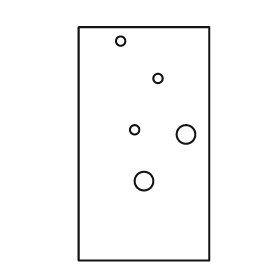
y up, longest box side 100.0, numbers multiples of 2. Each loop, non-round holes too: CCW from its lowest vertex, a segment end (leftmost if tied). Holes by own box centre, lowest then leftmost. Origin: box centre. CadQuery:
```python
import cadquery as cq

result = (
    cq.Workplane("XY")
    .moveTo(-28.0, -50.0)
    .lineTo(28.0, -50.0)
    .lineTo(28.0, 50.0)
    .lineTo(-28.0, 50.0)
    .close()
    .moveTo(0.0, -16.0)
    .circle(4.0)
    .moveTo(18.0, 4.0)
    .circle(4.0)
    .moveTo(-4.0, 6.0)
    .circle(2.0)
    .moveTo(6.0, 28.0)
    .circle(2.0)
    .moveTo(-10.0, 44.0)
    .circle(2.0)
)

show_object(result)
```